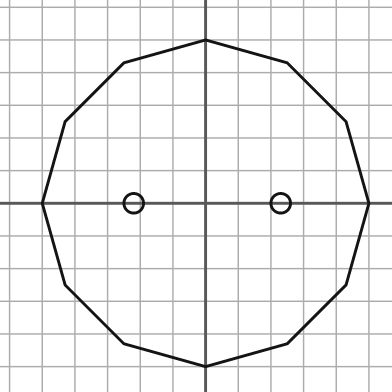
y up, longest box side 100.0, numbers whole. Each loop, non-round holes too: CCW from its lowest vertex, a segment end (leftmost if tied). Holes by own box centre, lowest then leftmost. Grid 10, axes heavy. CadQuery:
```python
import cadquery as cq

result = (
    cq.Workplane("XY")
    .moveTo(0.0, -50.0)
    .lineTo(25.0, -43.0)
    .lineTo(43.0, -25.0)
    .lineTo(50.0, 0.0)
    .lineTo(43.0, 25.0)
    .lineTo(25.0, 43.0)
    .lineTo(0.0, 50.0)
    .lineTo(-25.0, 43.0)
    .lineTo(-43.0, 25.0)
    .lineTo(-50.0, 0.0)
    .lineTo(-43.0, -25.0)
    .lineTo(-25.0, -43.0)
    .close()
    .moveTo(-22.0, 0.0)
    .circle(3.0)
    .moveTo(23.0, 0.0)
    .circle(3.0)
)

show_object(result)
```